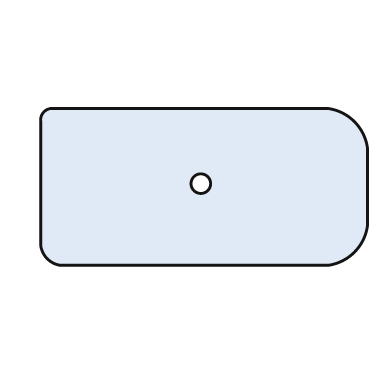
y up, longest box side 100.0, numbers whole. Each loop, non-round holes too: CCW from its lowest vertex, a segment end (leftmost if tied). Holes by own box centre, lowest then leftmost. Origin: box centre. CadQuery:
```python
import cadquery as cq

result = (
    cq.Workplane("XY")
    .moveTo(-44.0, -24.0)
    .lineTo(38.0, -24.0)
    .threePointArc((46.0, -20.0), (50.0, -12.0))
    .lineTo(50.0, 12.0)
    .threePointArc((46.0, 20.0), (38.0, 24.0))
    .lineTo(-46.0, 24.0)
    .threePointArc((-49.0, 23.0), (-50.0, 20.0))
    .lineTo(-50.0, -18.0)
    .threePointArc((-48.0, -22.0), (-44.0, -24.0))
    .close()
    .moveTo(-1.0, 1.0)
    .circle(3.0)
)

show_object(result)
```